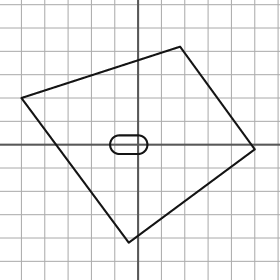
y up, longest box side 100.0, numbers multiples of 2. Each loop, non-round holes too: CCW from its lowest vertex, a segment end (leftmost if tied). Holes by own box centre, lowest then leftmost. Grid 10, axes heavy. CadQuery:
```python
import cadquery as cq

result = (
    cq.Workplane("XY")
    .moveTo(-4.0, -42.0)
    .lineTo(50.0, -2.0)
    .lineTo(18.0, 42.0)
    .lineTo(-50.0, 20.0)
    .close()
    .moveTo(-8.0, -4.0)
    .lineTo(0.0, -4.0)
    .threePointArc((4.0, 0.0), (0.0, 4.0))
    .lineTo(-8.0, 4.0)
    .threePointArc((-12.0, 0.0), (-8.0, -4.0))
    .close()
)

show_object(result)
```